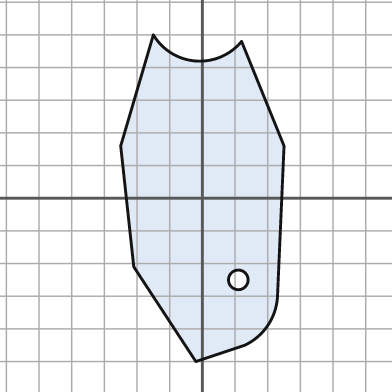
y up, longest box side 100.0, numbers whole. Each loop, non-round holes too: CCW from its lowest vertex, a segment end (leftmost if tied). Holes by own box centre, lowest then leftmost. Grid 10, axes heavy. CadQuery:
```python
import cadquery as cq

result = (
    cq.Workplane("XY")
    .moveTo(-2.0, -50.0)
    .lineTo(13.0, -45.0)
    .threePointArc((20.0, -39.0), (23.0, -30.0))
    .lineTo(25.0, 16.0)
    .lineTo(12.0, 48.0)
    .threePointArc((-2.0, 42.0), (-15.0, 50.0))
    .lineTo(-25.0, 16.0)
    .lineTo(-21.0, -21.0)
    .close()
    .moveTo(11.0, -25.0)
    .circle(3.0)
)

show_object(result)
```